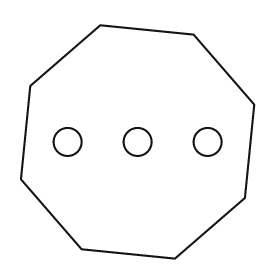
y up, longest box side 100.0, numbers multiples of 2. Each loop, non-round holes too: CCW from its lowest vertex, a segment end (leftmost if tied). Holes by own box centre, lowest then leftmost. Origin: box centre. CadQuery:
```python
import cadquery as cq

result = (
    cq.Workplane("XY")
    .moveTo(16.0, -50.0)
    .lineTo(46.0, -24.0)
    .lineTo(50.0, 16.0)
    .lineTo(24.0, 46.0)
    .lineTo(-16.0, 50.0)
    .lineTo(-46.0, 24.0)
    .lineTo(-50.0, -16.0)
    .lineTo(-24.0, -46.0)
    .close()
    .moveTo(-30.0, 0.0)
    .circle(6.0)
    .moveTo(0.0, 0.0)
    .circle(6.0)
    .moveTo(30.0, 0.0)
    .circle(6.0)
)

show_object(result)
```